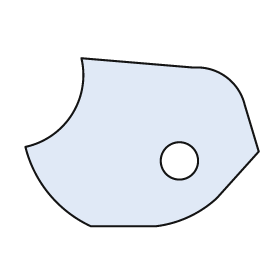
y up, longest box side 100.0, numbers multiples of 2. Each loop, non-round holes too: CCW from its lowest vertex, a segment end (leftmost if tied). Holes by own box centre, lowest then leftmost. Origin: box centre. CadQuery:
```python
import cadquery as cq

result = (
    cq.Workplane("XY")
    .moveTo(-22.0, -36.0)
    .lineTo(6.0, -36.0)
    .threePointArc((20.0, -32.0), (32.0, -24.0))
    .lineTo(50.0, -4.0)
    .lineTo(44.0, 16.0)
    .threePointArc((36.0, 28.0), (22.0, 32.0))
    .lineTo(-26.0, 36.0)
    .threePointArc((-30.0, 12.0), (-50.0, -2.0))
    .threePointArc((-40.0, -22.0), (-22.0, -36.0))
    .close()
    .moveTo(16.0, -8.0)
    .circle(8.0)
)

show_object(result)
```